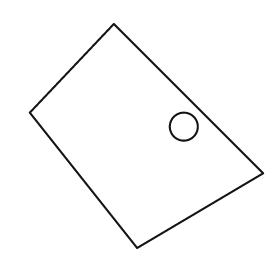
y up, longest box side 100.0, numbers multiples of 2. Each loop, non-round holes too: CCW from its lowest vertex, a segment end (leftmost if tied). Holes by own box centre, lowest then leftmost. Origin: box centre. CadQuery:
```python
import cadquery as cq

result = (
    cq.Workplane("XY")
    .moveTo(-4.0, -48.0)
    .lineTo(50.0, -16.0)
    .lineTo(-14.0, 48.0)
    .lineTo(-50.0, 10.0)
    .close()
    .moveTo(16.0, 4.0)
    .circle(6.0)
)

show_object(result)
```